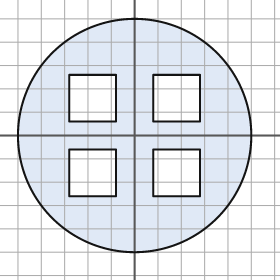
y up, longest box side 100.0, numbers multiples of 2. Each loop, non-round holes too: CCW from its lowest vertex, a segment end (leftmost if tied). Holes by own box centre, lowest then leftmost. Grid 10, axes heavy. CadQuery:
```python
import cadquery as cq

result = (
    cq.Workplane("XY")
    .moveTo(0.0, 0.0)
    .circle(50.0)
    .moveTo(-28.0, -26.0)
    .lineTo(-8.0, -26.0)
    .lineTo(-8.0, -6.0)
    .lineTo(-28.0, -6.0)
    .close()
    .moveTo(8.0, -26.0)
    .lineTo(28.0, -26.0)
    .lineTo(28.0, -6.0)
    .lineTo(8.0, -6.0)
    .close()
    .moveTo(-28.0, 6.0)
    .lineTo(-8.0, 6.0)
    .lineTo(-8.0, 26.0)
    .lineTo(-28.0, 26.0)
    .close()
    .moveTo(8.0, 6.0)
    .lineTo(28.0, 6.0)
    .lineTo(28.0, 26.0)
    .lineTo(8.0, 26.0)
    .close()
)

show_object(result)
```